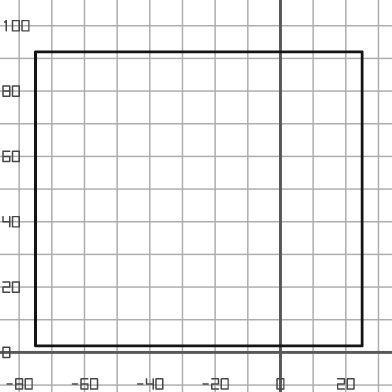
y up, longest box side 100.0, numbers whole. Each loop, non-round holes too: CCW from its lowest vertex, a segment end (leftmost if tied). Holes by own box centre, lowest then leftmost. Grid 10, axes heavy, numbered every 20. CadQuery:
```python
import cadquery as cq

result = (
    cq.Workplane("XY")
    .moveTo(-75.0, 2.0)
    .lineTo(25.0, 2.0)
    .lineTo(25.0, 92.0)
    .lineTo(-75.0, 92.0)
    .close()
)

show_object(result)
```